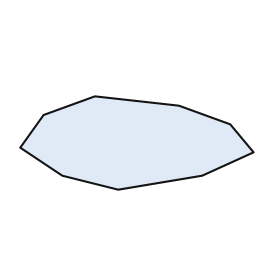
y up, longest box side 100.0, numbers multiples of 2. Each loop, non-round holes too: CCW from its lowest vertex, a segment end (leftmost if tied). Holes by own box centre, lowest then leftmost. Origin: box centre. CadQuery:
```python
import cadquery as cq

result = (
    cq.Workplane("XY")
    .moveTo(-8.0, -20.0)
    .lineTo(28.0, -14.0)
    .lineTo(50.0, -4.0)
    .lineTo(40.0, 8.0)
    .lineTo(18.0, 16.0)
    .lineTo(-18.0, 20.0)
    .lineTo(-40.0, 12.0)
    .lineTo(-50.0, -2.0)
    .lineTo(-32.0, -14.0)
    .close()
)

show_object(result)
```